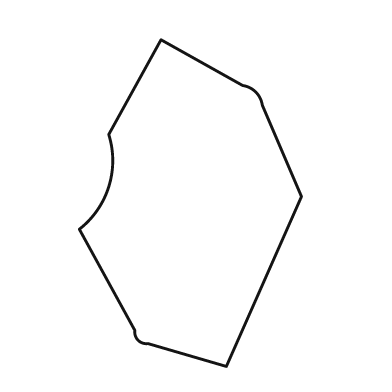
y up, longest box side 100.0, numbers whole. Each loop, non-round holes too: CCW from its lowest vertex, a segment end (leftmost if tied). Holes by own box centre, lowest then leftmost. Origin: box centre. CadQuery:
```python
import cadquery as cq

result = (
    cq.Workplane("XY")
    .moveTo(11.0, -50.0)
    .lineTo(34.0, 2.0)
    .lineTo(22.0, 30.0)
    .threePointArc((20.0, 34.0), (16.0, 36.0))
    .lineTo(-9.0, 50.0)
    .lineTo(-25.0, 21.0)
    .threePointArc((-25.0, 5.0), (-34.0, -8.0))
    .lineTo(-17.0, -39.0)
    .threePointArc((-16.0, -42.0), (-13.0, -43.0))
    .close()
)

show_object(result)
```